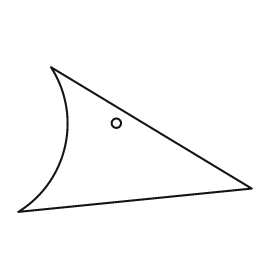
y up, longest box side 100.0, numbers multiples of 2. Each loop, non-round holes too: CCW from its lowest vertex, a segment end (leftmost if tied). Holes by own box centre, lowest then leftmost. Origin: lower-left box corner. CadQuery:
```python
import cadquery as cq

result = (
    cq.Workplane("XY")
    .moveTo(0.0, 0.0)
    .lineTo(100.0, 10.0)
    .lineTo(14.0, 62.0)
    .threePointArc((20.0, 28.0), (0.0, 0.0))
    .close()
    .moveTo(42.0, 38.0)
    .circle(2.0)
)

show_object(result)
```